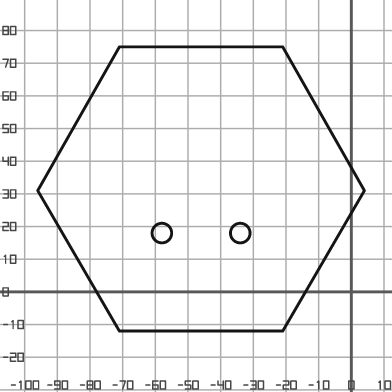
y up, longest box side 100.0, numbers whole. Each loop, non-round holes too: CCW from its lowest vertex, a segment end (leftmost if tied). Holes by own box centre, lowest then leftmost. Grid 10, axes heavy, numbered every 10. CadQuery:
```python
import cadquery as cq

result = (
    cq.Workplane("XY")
    .moveTo(-71.0, -12.0)
    .lineTo(-21.0, -12.0)
    .lineTo(4.0, 31.0)
    .lineTo(-21.0, 75.0)
    .lineTo(-71.0, 75.0)
    .lineTo(-96.0, 31.0)
    .close()
    .moveTo(-58.0, 18.0)
    .circle(3.0)
    .moveTo(-34.0, 18.0)
    .circle(3.0)
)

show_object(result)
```